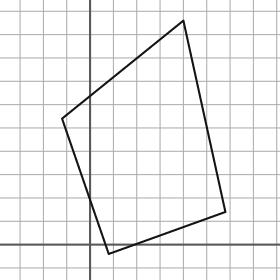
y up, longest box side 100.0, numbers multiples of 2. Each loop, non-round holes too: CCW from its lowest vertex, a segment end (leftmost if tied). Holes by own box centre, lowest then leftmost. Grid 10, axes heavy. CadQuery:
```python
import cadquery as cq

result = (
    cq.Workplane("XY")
    .moveTo(8.0, -4.0)
    .lineTo(58.0, 14.0)
    .lineTo(40.0, 96.0)
    .lineTo(-12.0, 54.0)
    .close()
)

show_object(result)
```